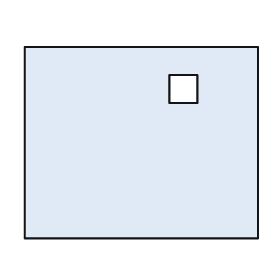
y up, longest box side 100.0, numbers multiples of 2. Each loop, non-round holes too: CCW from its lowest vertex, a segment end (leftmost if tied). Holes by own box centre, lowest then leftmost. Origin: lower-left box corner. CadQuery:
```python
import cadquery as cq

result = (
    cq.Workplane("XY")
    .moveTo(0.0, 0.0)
    .lineTo(100.0, 0.0)
    .lineTo(100.0, 82.0)
    .lineTo(0.0, 82.0)
    .close()
    .moveTo(62.0, 58.0)
    .lineTo(74.0, 58.0)
    .lineTo(74.0, 70.0)
    .lineTo(62.0, 70.0)
    .close()
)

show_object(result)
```